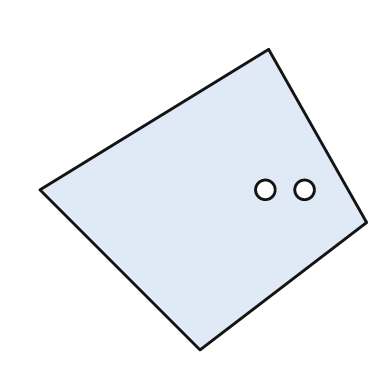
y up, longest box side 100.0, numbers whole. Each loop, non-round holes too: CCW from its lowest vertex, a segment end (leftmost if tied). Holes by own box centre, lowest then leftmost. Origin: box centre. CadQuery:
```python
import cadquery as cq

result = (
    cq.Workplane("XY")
    .moveTo(-1.0, -46.0)
    .lineTo(50.0, -7.0)
    .lineTo(20.0, 46.0)
    .lineTo(-50.0, 3.0)
    .close()
    .moveTo(19.0, 3.0)
    .circle(3.0)
    .moveTo(31.0, 3.0)
    .circle(3.0)
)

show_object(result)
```